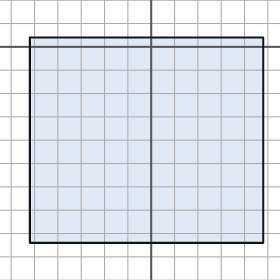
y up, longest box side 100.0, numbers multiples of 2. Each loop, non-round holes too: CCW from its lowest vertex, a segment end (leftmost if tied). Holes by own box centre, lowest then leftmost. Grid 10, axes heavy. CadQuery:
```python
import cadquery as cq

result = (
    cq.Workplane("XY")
    .moveTo(-52.0, -84.0)
    .lineTo(48.0, -84.0)
    .lineTo(48.0, 4.0)
    .lineTo(-52.0, 4.0)
    .close()
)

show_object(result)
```